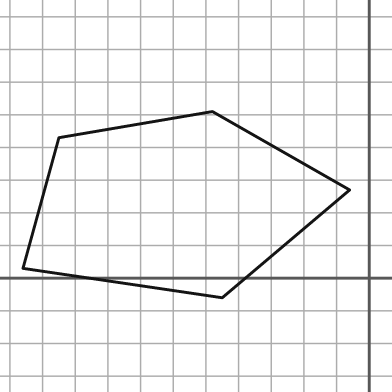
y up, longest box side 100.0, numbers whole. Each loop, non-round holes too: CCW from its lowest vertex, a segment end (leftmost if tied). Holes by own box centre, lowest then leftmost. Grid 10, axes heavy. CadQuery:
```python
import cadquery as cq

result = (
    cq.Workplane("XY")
    .moveTo(-45.0, -6.0)
    .lineTo(-6.0, 27.0)
    .lineTo(-48.0, 51.0)
    .lineTo(-95.0, 43.0)
    .lineTo(-106.0, 3.0)
    .close()
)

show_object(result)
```